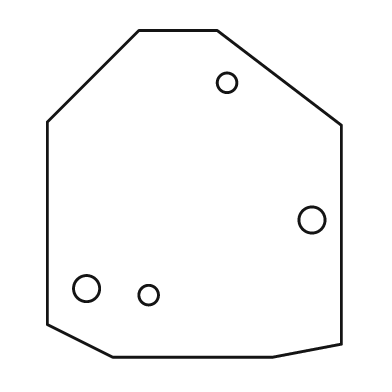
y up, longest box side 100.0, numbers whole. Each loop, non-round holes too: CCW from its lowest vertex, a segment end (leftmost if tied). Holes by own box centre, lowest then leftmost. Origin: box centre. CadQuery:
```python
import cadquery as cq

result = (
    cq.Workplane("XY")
    .moveTo(-25.0, -50.0)
    .lineTo(24.0, -50.0)
    .lineTo(45.0, -46.0)
    .lineTo(45.0, 21.0)
    .lineTo(7.0, 50.0)
    .lineTo(-17.0, 50.0)
    .lineTo(-45.0, 22.0)
    .lineTo(-45.0, -40.0)
    .close()
    .moveTo(-14.0, -31.0)
    .circle(3.0)
    .moveTo(-33.0, -29.0)
    .circle(4.0)
    .moveTo(36.0, -8.0)
    .circle(4.0)
    .moveTo(10.0, 34.0)
    .circle(3.0)
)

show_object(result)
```